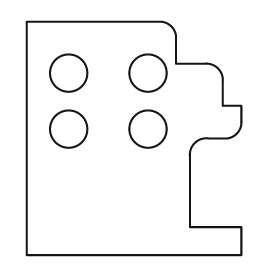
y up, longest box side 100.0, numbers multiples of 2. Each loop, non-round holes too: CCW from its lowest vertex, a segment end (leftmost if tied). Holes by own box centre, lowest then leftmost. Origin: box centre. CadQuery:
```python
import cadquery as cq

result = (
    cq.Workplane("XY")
    .moveTo(-46.0, -50.0)
    .lineTo(46.0, -50.0)
    .lineTo(46.0, -38.0)
    .lineTo(24.0, -38.0)
    .lineTo(24.0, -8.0)
    .threePointArc((26.0, -2.0), (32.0, 0.0))
    .lineTo(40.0, 0.0)
    .threePointArc((44.0, 2.0), (46.0, 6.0))
    .lineTo(46.0, 14.0)
    .lineTo(38.0, 14.0)
    .lineTo(38.0, 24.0)
    .threePointArc((36.0, 30.0), (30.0, 32.0))
    .lineTo(18.0, 32.0)
    .lineTo(18.0, 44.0)
    .threePointArc((16.0, 48.0), (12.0, 50.0))
    .lineTo(-46.0, 50.0)
    .close()
    .moveTo(-28.0, 4.0)
    .circle(8.0)
    .moveTo(6.0, 4.0)
    .circle(8.0)
    .moveTo(-28.0, 28.0)
    .circle(8.0)
    .moveTo(6.0, 28.0)
    .circle(8.0)
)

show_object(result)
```